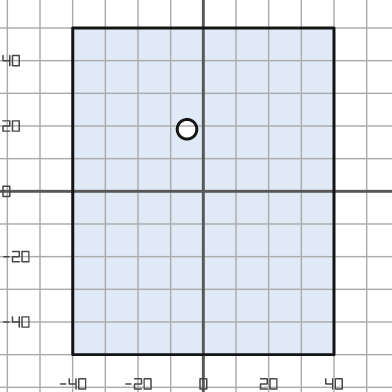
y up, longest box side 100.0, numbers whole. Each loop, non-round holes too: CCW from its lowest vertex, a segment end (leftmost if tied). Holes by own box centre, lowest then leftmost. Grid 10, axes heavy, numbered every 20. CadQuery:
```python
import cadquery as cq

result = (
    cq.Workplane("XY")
    .moveTo(-40.0, -50.0)
    .lineTo(40.0, -50.0)
    .lineTo(40.0, 50.0)
    .lineTo(-40.0, 50.0)
    .close()
    .moveTo(-5.0, 19.0)
    .circle(3.0)
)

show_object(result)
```